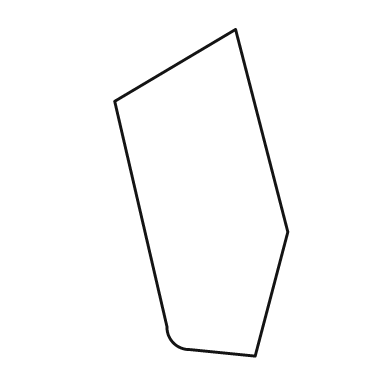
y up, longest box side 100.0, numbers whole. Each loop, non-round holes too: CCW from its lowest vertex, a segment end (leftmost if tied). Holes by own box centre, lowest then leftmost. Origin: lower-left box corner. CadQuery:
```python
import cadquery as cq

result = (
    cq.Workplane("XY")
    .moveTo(43.0, 0.0)
    .lineTo(53.0, 38.0)
    .lineTo(37.0, 100.0)
    .lineTo(0.0, 78.0)
    .lineTo(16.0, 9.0)
    .threePointArc((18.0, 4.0), (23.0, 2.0))
    .close()
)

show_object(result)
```